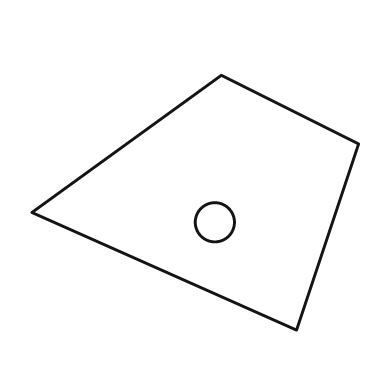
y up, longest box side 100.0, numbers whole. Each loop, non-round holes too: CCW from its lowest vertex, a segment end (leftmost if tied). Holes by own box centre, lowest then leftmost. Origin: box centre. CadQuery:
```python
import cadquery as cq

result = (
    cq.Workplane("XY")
    .moveTo(31.0, -39.0)
    .lineTo(50.0, 18.0)
    .lineTo(8.0, 39.0)
    .lineTo(-50.0, -3.0)
    .close()
    .moveTo(6.0, -6.0)
    .circle(6.0)
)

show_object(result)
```